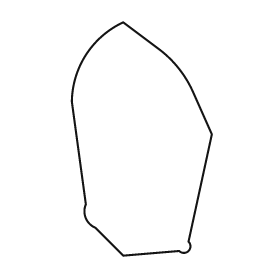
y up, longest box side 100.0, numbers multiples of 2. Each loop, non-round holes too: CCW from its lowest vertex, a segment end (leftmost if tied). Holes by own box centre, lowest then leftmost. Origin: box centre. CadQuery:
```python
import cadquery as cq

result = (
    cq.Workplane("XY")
    .moveTo(-8.0, -50.0)
    .lineTo(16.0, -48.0)
    .threePointArc((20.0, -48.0), (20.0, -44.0))
    .lineTo(30.0, 2.0)
    .lineTo(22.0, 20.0)
    .threePointArc((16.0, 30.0), (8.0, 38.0))
    .lineTo(-8.0, 50.0)
    .threePointArc((-24.0, 36.0), (-30.0, 16.0))
    .lineTo(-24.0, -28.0)
    .threePointArc((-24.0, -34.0), (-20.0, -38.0))
    .close()
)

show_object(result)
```